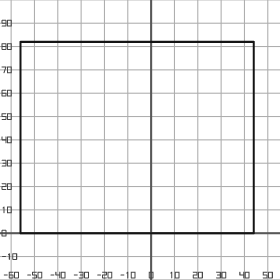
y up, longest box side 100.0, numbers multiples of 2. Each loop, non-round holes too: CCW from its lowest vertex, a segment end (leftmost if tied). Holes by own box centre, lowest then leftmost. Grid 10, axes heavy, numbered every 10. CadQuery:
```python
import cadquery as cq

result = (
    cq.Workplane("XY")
    .moveTo(-56.0, 0.0)
    .lineTo(44.0, 0.0)
    .lineTo(44.0, 82.0)
    .lineTo(-56.0, 82.0)
    .close()
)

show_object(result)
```